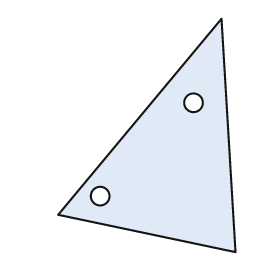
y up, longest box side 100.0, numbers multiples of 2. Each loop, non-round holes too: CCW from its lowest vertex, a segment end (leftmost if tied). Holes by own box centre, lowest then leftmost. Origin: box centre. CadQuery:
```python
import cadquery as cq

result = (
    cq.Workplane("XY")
    .moveTo(38.0, -50.0)
    .lineTo(32.0, 50.0)
    .lineTo(-38.0, -34.0)
    .close()
    .moveTo(-20.0, -26.0)
    .circle(4.0)
    .moveTo(20.0, 14.0)
    .circle(4.0)
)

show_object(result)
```